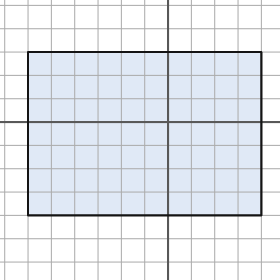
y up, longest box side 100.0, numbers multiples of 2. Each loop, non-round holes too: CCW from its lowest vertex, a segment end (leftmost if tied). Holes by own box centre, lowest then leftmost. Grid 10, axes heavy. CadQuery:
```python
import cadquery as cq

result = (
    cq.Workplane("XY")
    .moveTo(-60.0, -40.0)
    .lineTo(40.0, -40.0)
    .lineTo(40.0, 30.0)
    .lineTo(-60.0, 30.0)
    .close()
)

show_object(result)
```